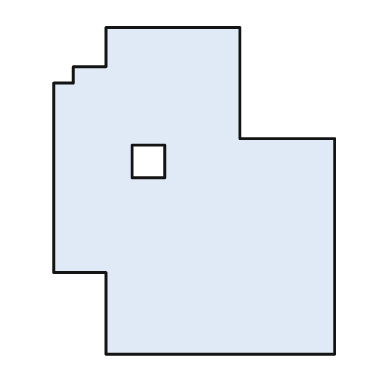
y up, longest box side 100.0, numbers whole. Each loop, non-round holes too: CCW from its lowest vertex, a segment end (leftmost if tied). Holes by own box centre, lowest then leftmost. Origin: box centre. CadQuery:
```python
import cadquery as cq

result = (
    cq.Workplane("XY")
    .moveTo(-27.0, -50.0)
    .lineTo(43.0, -50.0)
    .lineTo(43.0, 16.0)
    .lineTo(14.0, 16.0)
    .lineTo(14.0, 50.0)
    .lineTo(-27.0, 50.0)
    .lineTo(-27.0, 38.0)
    .lineTo(-37.0, 38.0)
    .lineTo(-37.0, 33.0)
    .lineTo(-43.0, 33.0)
    .lineTo(-43.0, -25.0)
    .lineTo(-27.0, -25.0)
    .close()
    .moveTo(-19.0, 4.0)
    .lineTo(-9.0, 4.0)
    .lineTo(-9.0, 14.0)
    .lineTo(-19.0, 14.0)
    .close()
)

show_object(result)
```